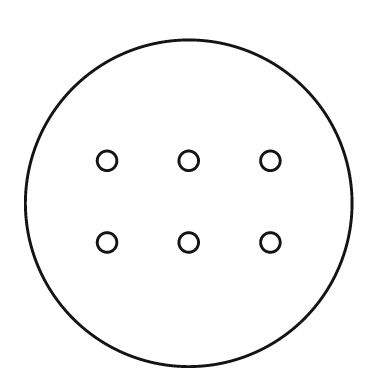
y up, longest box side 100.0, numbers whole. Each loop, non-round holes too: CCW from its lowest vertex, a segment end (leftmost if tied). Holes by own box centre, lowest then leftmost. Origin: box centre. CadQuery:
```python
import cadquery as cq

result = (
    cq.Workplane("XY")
    .moveTo(0.0, 0.0)
    .circle(50.0)
    .moveTo(-25.0, -12.0)
    .circle(3.0)
    .moveTo(0.0, -12.0)
    .circle(3.0)
    .moveTo(25.0, -12.0)
    .circle(3.0)
    .moveTo(-25.0, 13.0)
    .circle(3.0)
    .moveTo(0.0, 13.0)
    .circle(3.0)
    .moveTo(25.0, 13.0)
    .circle(3.0)
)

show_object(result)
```